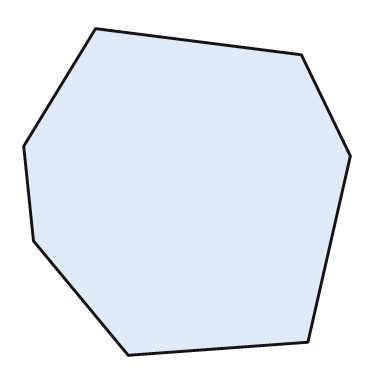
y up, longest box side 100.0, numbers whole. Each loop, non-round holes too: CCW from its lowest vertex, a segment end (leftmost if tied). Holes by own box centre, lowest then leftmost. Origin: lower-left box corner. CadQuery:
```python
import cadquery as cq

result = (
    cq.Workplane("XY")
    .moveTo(32.0, 0.0)
    .lineTo(87.0, 4.0)
    .lineTo(100.0, 61.0)
    .lineTo(85.0, 92.0)
    .lineTo(22.0, 100.0)
    .lineTo(0.0, 64.0)
    .lineTo(3.0, 35.0)
    .close()
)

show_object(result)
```